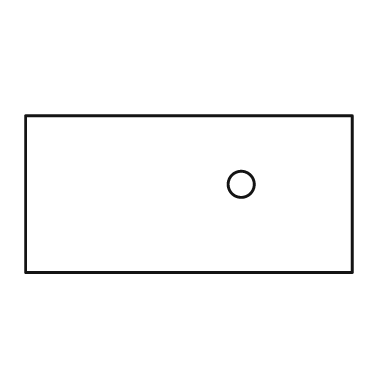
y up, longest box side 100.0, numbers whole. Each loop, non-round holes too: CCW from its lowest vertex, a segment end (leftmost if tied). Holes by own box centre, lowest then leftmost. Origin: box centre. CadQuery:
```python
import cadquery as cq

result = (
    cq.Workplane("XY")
    .moveTo(-50.0, -24.0)
    .lineTo(50.0, -24.0)
    .lineTo(50.0, 24.0)
    .lineTo(-50.0, 24.0)
    .close()
    .moveTo(16.0, 3.0)
    .circle(4.0)
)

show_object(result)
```